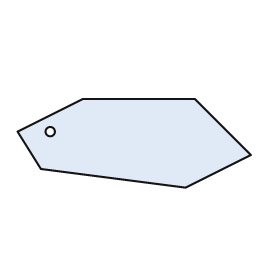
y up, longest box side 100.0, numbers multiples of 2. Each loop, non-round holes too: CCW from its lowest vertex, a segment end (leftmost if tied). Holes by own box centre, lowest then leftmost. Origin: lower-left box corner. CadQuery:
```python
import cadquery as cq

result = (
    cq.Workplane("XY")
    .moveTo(72.0, 0.0)
    .lineTo(100.0, 14.0)
    .lineTo(76.0, 38.0)
    .lineTo(28.0, 38.0)
    .lineTo(0.0, 24.0)
    .lineTo(10.0, 8.0)
    .close()
    .moveTo(14.0, 24.0)
    .circle(2.0)
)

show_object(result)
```